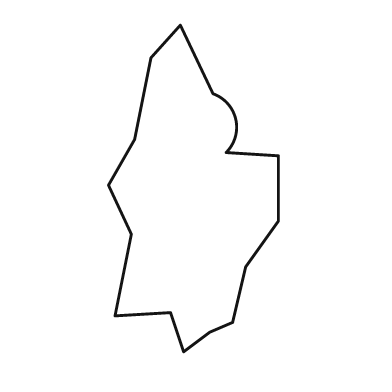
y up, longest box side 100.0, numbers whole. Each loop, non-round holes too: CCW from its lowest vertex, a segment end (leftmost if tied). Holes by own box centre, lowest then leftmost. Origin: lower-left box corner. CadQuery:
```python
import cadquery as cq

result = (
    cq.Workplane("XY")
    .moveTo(23.0, 0.0)
    .lineTo(31.0, 6.0)
    .lineTo(38.0, 9.0)
    .lineTo(42.0, 26.0)
    .lineTo(52.0, 40.0)
    .lineTo(52.0, 60.0)
    .lineTo(36.0, 61.0)
    .threePointArc((39.0, 71.0), (32.0, 79.0))
    .lineTo(22.0, 100.0)
    .lineTo(13.0, 90.0)
    .lineTo(8.0, 65.0)
    .lineTo(0.0, 51.0)
    .lineTo(7.0, 36.0)
    .lineTo(2.0, 11.0)
    .lineTo(19.0, 12.0)
    .close()
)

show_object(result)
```